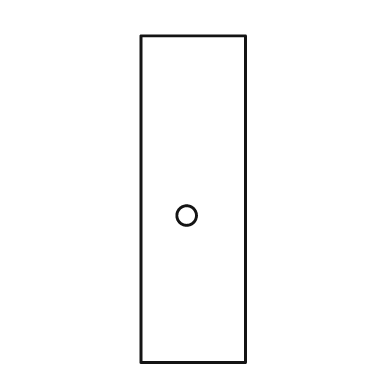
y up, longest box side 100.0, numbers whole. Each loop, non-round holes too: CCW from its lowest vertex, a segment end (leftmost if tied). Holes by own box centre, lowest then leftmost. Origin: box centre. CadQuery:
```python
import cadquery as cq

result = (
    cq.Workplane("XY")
    .moveTo(-16.0, -50.0)
    .lineTo(16.0, -50.0)
    .lineTo(16.0, 50.0)
    .lineTo(-16.0, 50.0)
    .close()
    .moveTo(-2.0, -5.0)
    .circle(3.0)
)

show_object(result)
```